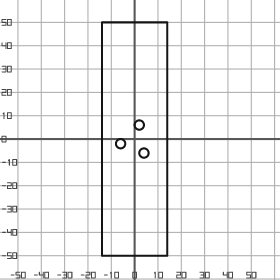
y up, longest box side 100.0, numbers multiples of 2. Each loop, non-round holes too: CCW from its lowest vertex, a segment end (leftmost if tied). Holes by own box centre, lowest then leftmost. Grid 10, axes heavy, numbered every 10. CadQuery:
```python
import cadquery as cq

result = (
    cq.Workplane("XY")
    .moveTo(-14.0, -50.0)
    .lineTo(14.0, -50.0)
    .lineTo(14.0, 50.0)
    .lineTo(-14.0, 50.0)
    .close()
    .moveTo(4.0, -6.0)
    .circle(2.0)
    .moveTo(-6.0, -2.0)
    .circle(2.0)
    .moveTo(2.0, 6.0)
    .circle(2.0)
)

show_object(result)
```